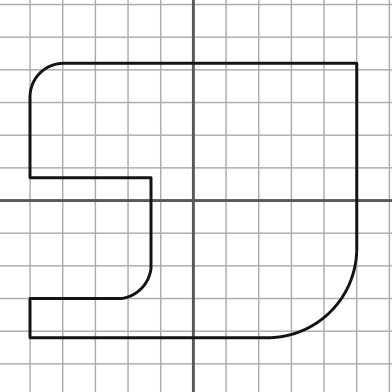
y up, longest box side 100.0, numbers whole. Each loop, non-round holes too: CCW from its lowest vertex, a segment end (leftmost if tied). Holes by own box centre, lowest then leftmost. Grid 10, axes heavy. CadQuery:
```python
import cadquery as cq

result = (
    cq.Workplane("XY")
    .moveTo(-50.0, -42.0)
    .lineTo(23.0, -42.0)
    .threePointArc((42.0, -34.0), (50.0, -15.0))
    .lineTo(50.0, 42.0)
    .lineTo(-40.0, 42.0)
    .threePointArc((-47.0, 39.0), (-50.0, 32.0))
    .lineTo(-50.0, 7.0)
    .lineTo(-13.0, 7.0)
    .lineTo(-13.0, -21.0)
    .threePointArc((-16.0, -27.0), (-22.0, -30.0))
    .lineTo(-50.0, -30.0)
    .close()
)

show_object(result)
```